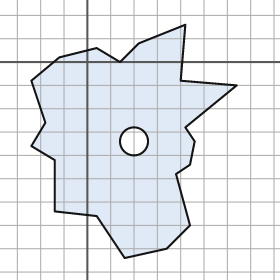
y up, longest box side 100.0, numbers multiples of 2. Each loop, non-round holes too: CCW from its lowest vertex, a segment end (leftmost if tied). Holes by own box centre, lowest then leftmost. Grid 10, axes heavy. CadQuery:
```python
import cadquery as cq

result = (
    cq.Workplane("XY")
    .moveTo(16.0, -84.0)
    .lineTo(34.0, -80.0)
    .lineTo(44.0, -70.0)
    .lineTo(38.0, -48.0)
    .lineTo(44.0, -44.0)
    .lineTo(46.0, -34.0)
    .lineTo(42.0, -28.0)
    .lineTo(64.0, -10.0)
    .lineTo(40.0, -8.0)
    .lineTo(42.0, 16.0)
    .lineTo(22.0, 8.0)
    .lineTo(14.0, 0.0)
    .lineTo(4.0, 6.0)
    .lineTo(-12.0, 2.0)
    .lineTo(-24.0, -8.0)
    .lineTo(-18.0, -26.0)
    .lineTo(-24.0, -36.0)
    .lineTo(-14.0, -42.0)
    .lineTo(-14.0, -64.0)
    .lineTo(4.0, -66.0)
    .close()
    .moveTo(20.0, -34.0)
    .circle(6.0)
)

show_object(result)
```